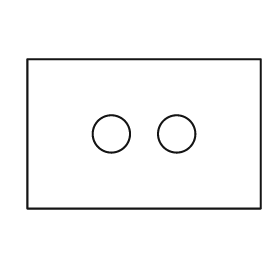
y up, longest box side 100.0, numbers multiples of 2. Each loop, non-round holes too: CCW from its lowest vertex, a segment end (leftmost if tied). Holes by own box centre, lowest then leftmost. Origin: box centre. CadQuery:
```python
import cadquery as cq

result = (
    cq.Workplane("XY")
    .moveTo(-50.0, -32.0)
    .lineTo(50.0, -32.0)
    .lineTo(50.0, 32.0)
    .lineTo(-50.0, 32.0)
    .close()
    .moveTo(-14.0, 0.0)
    .circle(8.0)
    .moveTo(14.0, 0.0)
    .circle(8.0)
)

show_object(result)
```